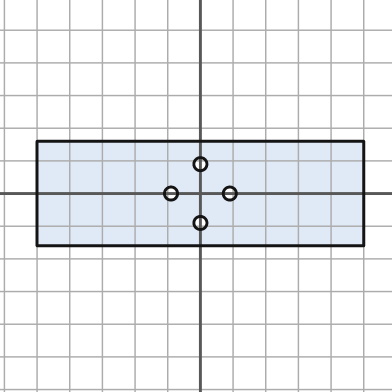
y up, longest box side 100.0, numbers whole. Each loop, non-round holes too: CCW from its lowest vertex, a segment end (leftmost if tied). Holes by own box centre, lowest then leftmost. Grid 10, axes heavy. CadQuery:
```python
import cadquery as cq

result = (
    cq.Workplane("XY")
    .moveTo(-50.0, -16.0)
    .lineTo(50.0, -16.0)
    .lineTo(50.0, 16.0)
    .lineTo(-50.0, 16.0)
    .close()
    .moveTo(0.0, -9.0)
    .circle(2.0)
    .moveTo(-9.0, 0.0)
    .circle(2.0)
    .moveTo(9.0, 0.0)
    .circle(2.0)
    .moveTo(0.0, 9.0)
    .circle(2.0)
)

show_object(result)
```